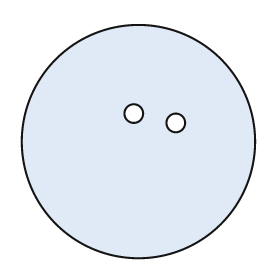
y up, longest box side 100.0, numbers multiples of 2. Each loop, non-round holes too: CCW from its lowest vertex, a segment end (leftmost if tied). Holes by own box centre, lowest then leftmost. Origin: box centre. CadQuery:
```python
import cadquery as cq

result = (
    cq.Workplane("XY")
    .moveTo(0.0, 0.0)
    .circle(50.0)
    .moveTo(16.0, 8.0)
    .circle(4.0)
    .moveTo(-2.0, 12.0)
    .circle(4.0)
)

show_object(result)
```